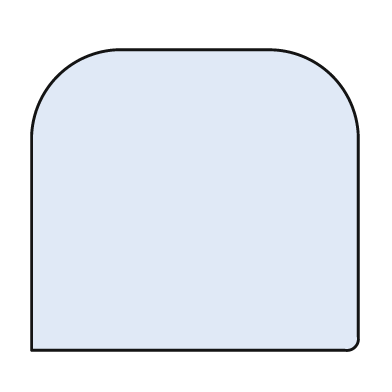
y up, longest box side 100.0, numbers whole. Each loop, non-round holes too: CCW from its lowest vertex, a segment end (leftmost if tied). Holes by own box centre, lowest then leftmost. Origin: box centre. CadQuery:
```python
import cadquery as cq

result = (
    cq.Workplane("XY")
    .moveTo(-50.0, -46.0)
    .lineTo(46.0, -46.0)
    .threePointArc((49.0, -45.0), (50.0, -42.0))
    .lineTo(50.0, 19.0)
    .threePointArc((42.0, 38.0), (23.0, 46.0))
    .lineTo(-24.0, 46.0)
    .threePointArc((-42.0, 38.0), (-50.0, 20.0))
    .close()
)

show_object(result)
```